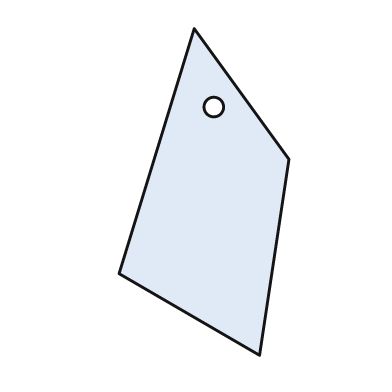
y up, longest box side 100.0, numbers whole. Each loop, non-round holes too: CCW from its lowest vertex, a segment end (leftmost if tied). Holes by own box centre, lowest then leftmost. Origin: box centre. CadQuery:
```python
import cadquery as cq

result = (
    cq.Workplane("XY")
    .moveTo(17.0, -50.0)
    .lineTo(26.0, 10.0)
    .lineTo(-3.0, 50.0)
    .lineTo(-26.0, -25.0)
    .close()
    .moveTo(3.0, 26.0)
    .circle(3.0)
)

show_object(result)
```